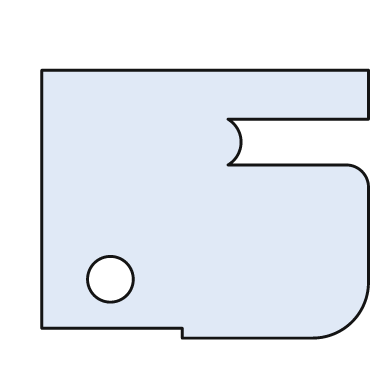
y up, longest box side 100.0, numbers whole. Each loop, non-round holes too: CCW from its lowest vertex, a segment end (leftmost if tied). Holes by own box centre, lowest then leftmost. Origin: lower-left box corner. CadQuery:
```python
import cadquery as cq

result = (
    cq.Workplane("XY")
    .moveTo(43.0, 0.0)
    .lineTo(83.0, 0.0)
    .threePointArc((95.0, 5.0), (100.0, 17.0))
    .lineTo(100.0, 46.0)
    .threePointArc((98.0, 51.0), (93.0, 53.0))
    .lineTo(57.0, 53.0)
    .threePointArc((61.0, 60.0), (57.0, 67.0))
    .lineTo(100.0, 67.0)
    .lineTo(100.0, 82.0)
    .lineTo(0.0, 82.0)
    .lineTo(0.0, 3.0)
    .lineTo(43.0, 3.0)
    .close()
    .moveTo(21.0, 18.0)
    .circle(7.0)
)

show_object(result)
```